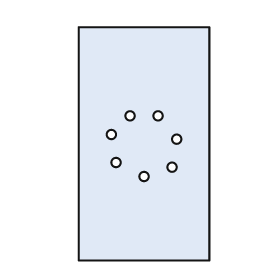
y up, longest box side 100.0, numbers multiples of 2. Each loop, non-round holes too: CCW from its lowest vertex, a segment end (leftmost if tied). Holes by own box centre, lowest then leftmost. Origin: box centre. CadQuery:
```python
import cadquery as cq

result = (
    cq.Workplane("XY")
    .moveTo(-28.0, -50.0)
    .lineTo(28.0, -50.0)
    .lineTo(28.0, 50.0)
    .lineTo(-28.0, 50.0)
    .close()
    .moveTo(0.0, -14.0)
    .circle(2.0)
    .moveTo(12.0, -10.0)
    .circle(2.0)
    .moveTo(-12.0, -8.0)
    .circle(2.0)
    .moveTo(14.0, 2.0)
    .circle(2.0)
    .moveTo(-14.0, 4.0)
    .circle(2.0)
    .moveTo(-6.0, 12.0)
    .circle(2.0)
    .moveTo(6.0, 12.0)
    .circle(2.0)
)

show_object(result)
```